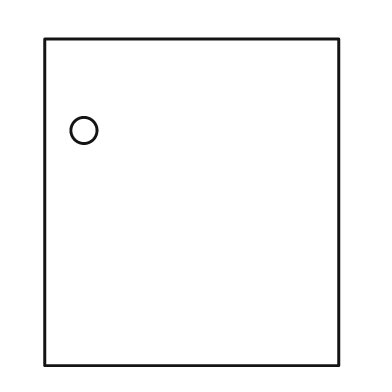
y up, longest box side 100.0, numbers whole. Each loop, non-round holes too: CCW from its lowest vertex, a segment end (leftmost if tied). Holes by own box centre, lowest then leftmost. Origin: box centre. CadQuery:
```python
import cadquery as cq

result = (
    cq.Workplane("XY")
    .moveTo(-45.0, -50.0)
    .lineTo(45.0, -50.0)
    .lineTo(45.0, 50.0)
    .lineTo(-45.0, 50.0)
    .close()
    .moveTo(-33.0, 22.0)
    .circle(4.0)
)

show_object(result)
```